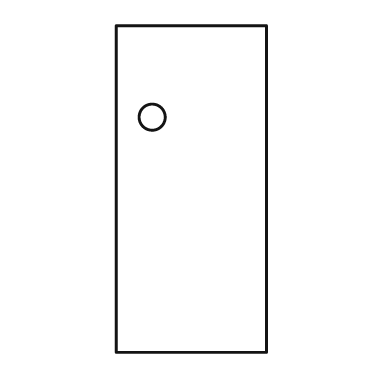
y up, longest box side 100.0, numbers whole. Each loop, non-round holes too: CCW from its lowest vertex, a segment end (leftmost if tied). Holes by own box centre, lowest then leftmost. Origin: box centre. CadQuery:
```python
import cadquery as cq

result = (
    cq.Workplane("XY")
    .moveTo(-23.0, -50.0)
    .lineTo(23.0, -50.0)
    .lineTo(23.0, 50.0)
    .lineTo(-23.0, 50.0)
    .close()
    .moveTo(-12.0, 22.0)
    .circle(4.0)
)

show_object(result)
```